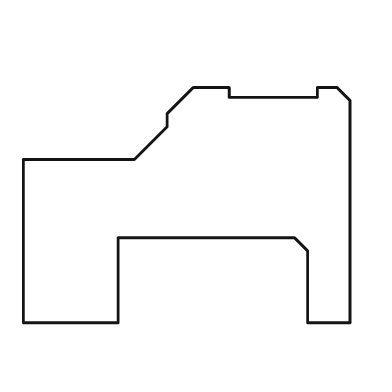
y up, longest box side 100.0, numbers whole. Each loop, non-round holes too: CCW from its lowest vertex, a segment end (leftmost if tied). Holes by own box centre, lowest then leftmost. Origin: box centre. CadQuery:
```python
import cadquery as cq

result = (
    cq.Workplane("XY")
    .moveTo(-50.0, -36.0)
    .lineTo(-21.0, -36.0)
    .lineTo(-21.0, -10.0)
    .lineTo(33.0, -10.0)
    .lineTo(37.0, -14.0)
    .lineTo(37.0, -36.0)
    .lineTo(50.0, -36.0)
    .lineTo(50.0, 32.0)
    .lineTo(46.0, 36.0)
    .lineTo(40.0, 36.0)
    .lineTo(40.0, 33.0)
    .lineTo(13.0, 33.0)
    .lineTo(13.0, 36.0)
    .lineTo(2.0, 36.0)
    .lineTo(-6.0, 28.0)
    .lineTo(-6.0, 24.0)
    .lineTo(-16.0, 14.0)
    .lineTo(-50.0, 14.0)
    .close()
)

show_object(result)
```